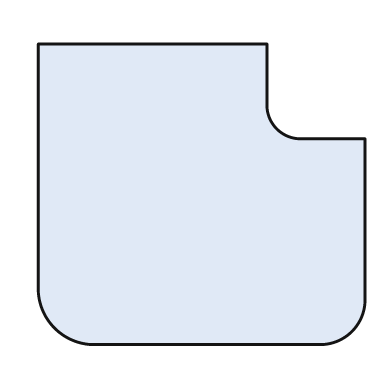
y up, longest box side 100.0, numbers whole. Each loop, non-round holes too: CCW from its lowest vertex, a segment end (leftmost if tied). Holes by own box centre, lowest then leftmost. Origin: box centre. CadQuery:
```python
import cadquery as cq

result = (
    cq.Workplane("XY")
    .moveTo(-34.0, -46.0)
    .lineTo(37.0, -46.0)
    .threePointArc((46.0, -42.0), (50.0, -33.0))
    .lineTo(50.0, 17.0)
    .lineTo(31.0, 17.0)
    .threePointArc((23.0, 20.0), (20.0, 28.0))
    .lineTo(20.0, 46.0)
    .lineTo(-50.0, 46.0)
    .lineTo(-50.0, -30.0)
    .threePointArc((-45.0, -41.0), (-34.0, -46.0))
    .close()
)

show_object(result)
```